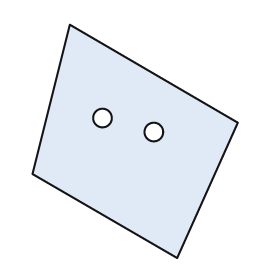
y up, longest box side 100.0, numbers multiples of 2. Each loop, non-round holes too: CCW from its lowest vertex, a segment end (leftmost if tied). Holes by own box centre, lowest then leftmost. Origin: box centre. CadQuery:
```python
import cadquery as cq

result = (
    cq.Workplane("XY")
    .moveTo(18.0, -50.0)
    .lineTo(44.0, 8.0)
    .lineTo(-28.0, 50.0)
    .lineTo(-44.0, -14.0)
    .close()
    .moveTo(8.0, 4.0)
    .circle(4.0)
    .moveTo(-14.0, 10.0)
    .circle(4.0)
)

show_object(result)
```